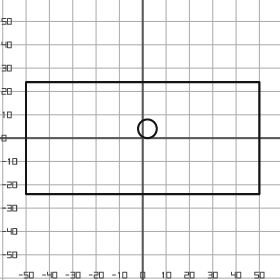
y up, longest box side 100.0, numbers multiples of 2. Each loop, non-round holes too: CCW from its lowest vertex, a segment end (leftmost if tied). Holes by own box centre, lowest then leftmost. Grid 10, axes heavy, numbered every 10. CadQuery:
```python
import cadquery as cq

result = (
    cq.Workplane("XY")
    .moveTo(-50.0, -24.0)
    .lineTo(50.0, -24.0)
    .lineTo(50.0, 24.0)
    .lineTo(-50.0, 24.0)
    .close()
    .moveTo(2.0, 4.0)
    .circle(4.0)
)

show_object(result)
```